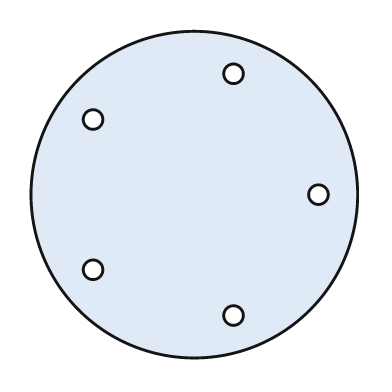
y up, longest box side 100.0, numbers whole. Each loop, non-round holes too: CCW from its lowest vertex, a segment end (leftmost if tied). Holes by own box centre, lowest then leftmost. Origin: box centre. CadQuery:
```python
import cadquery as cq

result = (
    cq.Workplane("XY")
    .moveTo(0.0, 0.0)
    .circle(50.0)
    .moveTo(12.0, -37.0)
    .circle(3.0)
    .moveTo(-31.0, -23.0)
    .circle(3.0)
    .moveTo(38.0, 0.0)
    .circle(3.0)
    .moveTo(-31.0, 23.0)
    .circle(3.0)
    .moveTo(12.0, 37.0)
    .circle(3.0)
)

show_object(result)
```